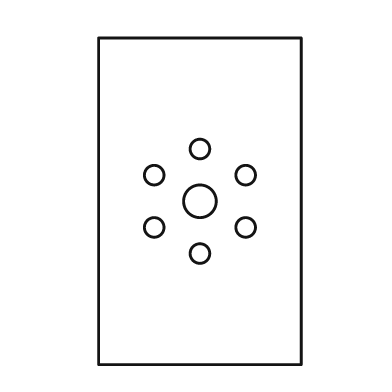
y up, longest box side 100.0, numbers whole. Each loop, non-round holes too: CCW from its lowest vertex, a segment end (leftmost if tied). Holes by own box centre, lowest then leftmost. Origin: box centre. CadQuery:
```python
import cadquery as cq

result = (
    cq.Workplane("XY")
    .moveTo(-31.0, -50.0)
    .lineTo(31.0, -50.0)
    .lineTo(31.0, 50.0)
    .lineTo(-31.0, 50.0)
    .close()
    .moveTo(0.0, -16.0)
    .circle(3.0)
    .moveTo(-14.0, -8.0)
    .circle(3.0)
    .moveTo(14.0, -8.0)
    .circle(3.0)
    .moveTo(0.0, 0.0)
    .circle(5.0)
    .moveTo(-14.0, 8.0)
    .circle(3.0)
    .moveTo(14.0, 8.0)
    .circle(3.0)
    .moveTo(0.0, 16.0)
    .circle(3.0)
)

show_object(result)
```